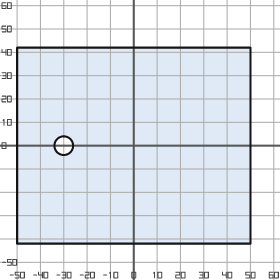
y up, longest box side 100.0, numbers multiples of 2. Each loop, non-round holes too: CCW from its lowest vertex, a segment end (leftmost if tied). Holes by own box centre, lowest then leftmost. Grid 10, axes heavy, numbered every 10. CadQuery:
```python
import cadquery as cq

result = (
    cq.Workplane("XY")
    .moveTo(-50.0, -42.0)
    .lineTo(50.0, -42.0)
    .lineTo(50.0, 42.0)
    .lineTo(-50.0, 42.0)
    .close()
    .moveTo(-30.0, 0.0)
    .circle(4.0)
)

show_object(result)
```